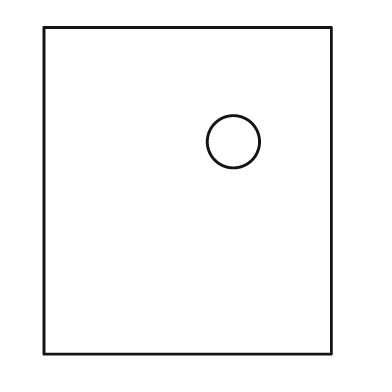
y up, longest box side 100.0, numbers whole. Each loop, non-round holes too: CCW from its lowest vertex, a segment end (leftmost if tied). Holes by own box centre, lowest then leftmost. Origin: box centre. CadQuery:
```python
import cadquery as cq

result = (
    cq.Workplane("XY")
    .moveTo(-44.0, -50.0)
    .lineTo(44.0, -50.0)
    .lineTo(44.0, 50.0)
    .lineTo(-44.0, 50.0)
    .close()
    .moveTo(14.0, 15.0)
    .circle(8.0)
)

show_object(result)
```